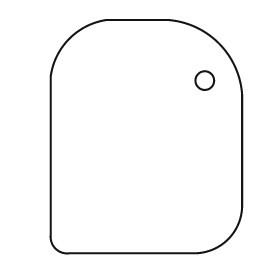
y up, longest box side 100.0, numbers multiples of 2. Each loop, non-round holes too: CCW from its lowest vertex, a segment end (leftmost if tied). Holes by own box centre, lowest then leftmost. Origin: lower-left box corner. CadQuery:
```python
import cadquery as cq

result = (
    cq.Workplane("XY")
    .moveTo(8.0, 0.0)
    .lineTo(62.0, 0.0)
    .threePointArc((76.0, 6.0), (82.0, 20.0))
    .lineTo(82.0, 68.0)
    .threePointArc((72.0, 90.0), (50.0, 100.0))
    .lineTo(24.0, 100.0)
    .threePointArc((8.0, 92.0), (0.0, 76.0))
    .lineTo(0.0, 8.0)
    .threePointArc((2.0, 2.0), (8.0, 0.0))
    .close()
    .moveTo(66.0, 74.0)
    .circle(4.0)
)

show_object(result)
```